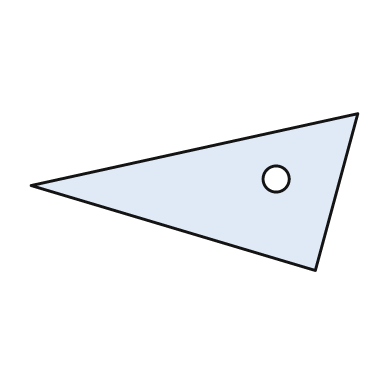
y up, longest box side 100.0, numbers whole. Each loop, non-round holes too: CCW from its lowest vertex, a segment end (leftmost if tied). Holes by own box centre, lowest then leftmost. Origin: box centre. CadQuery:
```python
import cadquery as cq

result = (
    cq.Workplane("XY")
    .moveTo(37.0, -24.0)
    .lineTo(50.0, 24.0)
    .lineTo(-50.0, 2.0)
    .close()
    .moveTo(25.0, 4.0)
    .circle(4.0)
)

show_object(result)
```